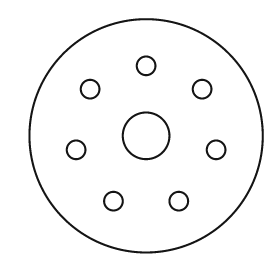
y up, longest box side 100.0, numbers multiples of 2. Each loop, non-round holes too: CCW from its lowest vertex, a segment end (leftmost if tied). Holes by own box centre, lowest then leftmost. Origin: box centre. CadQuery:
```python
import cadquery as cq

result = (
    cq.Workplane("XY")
    .moveTo(0.0, 0.0)
    .circle(50.0)
    .moveTo(-14.0, -28.0)
    .circle(4.0)
    .moveTo(14.0, -28.0)
    .circle(4.0)
    .moveTo(-30.0, -6.0)
    .circle(4.0)
    .moveTo(30.0, -6.0)
    .circle(4.0)
    .moveTo(0.0, 0.0)
    .circle(10.0)
    .moveTo(-24.0, 20.0)
    .circle(4.0)
    .moveTo(24.0, 20.0)
    .circle(4.0)
    .moveTo(0.0, 30.0)
    .circle(4.0)
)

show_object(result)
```